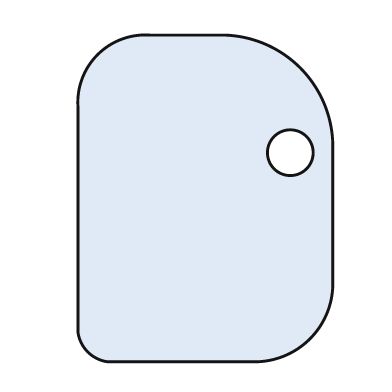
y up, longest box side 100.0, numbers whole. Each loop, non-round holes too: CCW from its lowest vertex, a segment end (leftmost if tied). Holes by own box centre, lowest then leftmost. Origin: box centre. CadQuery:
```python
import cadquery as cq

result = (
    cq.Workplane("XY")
    .moveTo(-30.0, -50.0)
    .lineTo(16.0, -50.0)
    .threePointArc((32.0, -43.0), (39.0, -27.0))
    .lineTo(39.0, 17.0)
    .threePointArc((29.0, 40.0), (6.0, 50.0))
    .lineTo(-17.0, 50.0)
    .threePointArc((-33.0, 44.0), (-39.0, 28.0))
    .lineTo(-39.0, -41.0)
    .threePointArc((-36.0, -47.0), (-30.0, -50.0))
    .close()
    .moveTo(26.0, 14.0)
    .circle(7.0)
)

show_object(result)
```